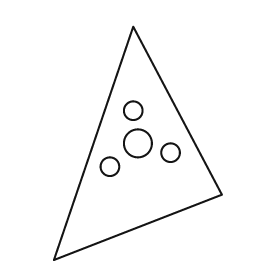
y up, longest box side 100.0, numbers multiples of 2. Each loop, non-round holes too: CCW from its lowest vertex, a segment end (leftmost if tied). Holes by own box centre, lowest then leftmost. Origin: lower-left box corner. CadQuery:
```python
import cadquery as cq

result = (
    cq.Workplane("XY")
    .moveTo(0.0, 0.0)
    .lineTo(72.0, 28.0)
    .lineTo(34.0, 100.0)
    .close()
    .moveTo(24.0, 40.0)
    .circle(4.0)
    .moveTo(50.0, 46.0)
    .circle(4.0)
    .moveTo(36.0, 50.0)
    .circle(6.0)
    .moveTo(34.0, 64.0)
    .circle(4.0)
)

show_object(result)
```